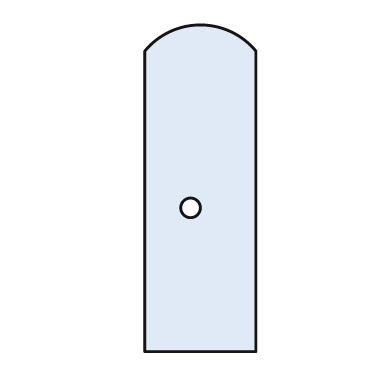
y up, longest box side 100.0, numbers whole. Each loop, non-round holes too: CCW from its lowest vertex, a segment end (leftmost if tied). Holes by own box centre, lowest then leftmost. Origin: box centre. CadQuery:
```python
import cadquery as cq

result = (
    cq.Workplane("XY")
    .moveTo(-17.0, -50.0)
    .lineTo(17.0, -50.0)
    .lineTo(17.0, 42.0)
    .threePointArc((0.0, 50.0), (-17.0, 42.0))
    .close()
    .moveTo(-3.0, -6.0)
    .circle(3.0)
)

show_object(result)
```